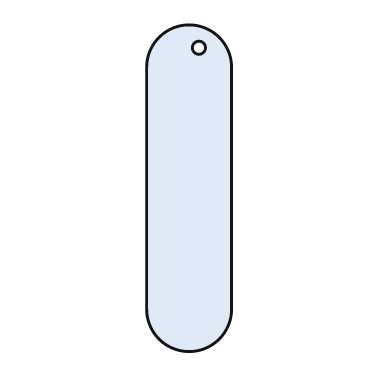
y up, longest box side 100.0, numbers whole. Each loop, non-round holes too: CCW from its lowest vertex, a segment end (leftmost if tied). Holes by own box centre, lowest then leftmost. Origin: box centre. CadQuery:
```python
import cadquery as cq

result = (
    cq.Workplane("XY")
    .moveTo(-13.0, -37.0)
    .threePointArc((0.0, -50.0), (13.0, -37.0))
    .lineTo(13.0, 37.0)
    .threePointArc((0.0, 50.0), (-13.0, 37.0))
    .close()
    .moveTo(3.0, 43.0)
    .circle(2.0)
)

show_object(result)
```